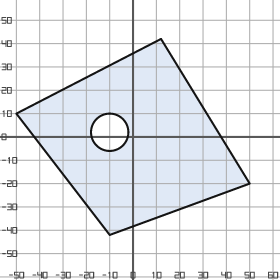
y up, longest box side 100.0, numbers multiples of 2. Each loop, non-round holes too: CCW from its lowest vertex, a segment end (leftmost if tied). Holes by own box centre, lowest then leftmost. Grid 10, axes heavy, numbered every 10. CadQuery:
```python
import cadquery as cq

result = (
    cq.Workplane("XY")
    .moveTo(-10.0, -42.0)
    .lineTo(50.0, -20.0)
    .lineTo(12.0, 42.0)
    .lineTo(-50.0, 10.0)
    .close()
    .moveTo(-10.0, 2.0)
    .circle(8.0)
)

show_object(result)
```